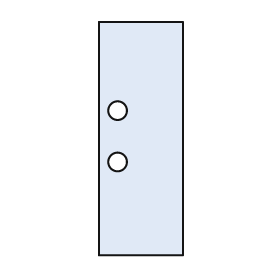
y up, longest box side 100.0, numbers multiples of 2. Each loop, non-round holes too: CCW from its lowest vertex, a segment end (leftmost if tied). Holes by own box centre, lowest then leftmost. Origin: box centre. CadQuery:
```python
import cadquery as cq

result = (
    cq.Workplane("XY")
    .moveTo(-18.0, -50.0)
    .lineTo(18.0, -50.0)
    .lineTo(18.0, 50.0)
    .lineTo(-18.0, 50.0)
    .close()
    .moveTo(-10.0, -10.0)
    .circle(4.0)
    .moveTo(-10.0, 12.0)
    .circle(4.0)
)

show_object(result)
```